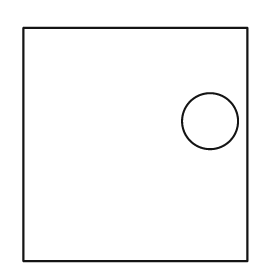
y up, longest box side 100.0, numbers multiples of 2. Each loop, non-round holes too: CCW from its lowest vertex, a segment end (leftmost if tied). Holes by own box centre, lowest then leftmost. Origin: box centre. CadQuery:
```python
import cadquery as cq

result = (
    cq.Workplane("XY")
    .moveTo(-48.0, -50.0)
    .lineTo(48.0, -50.0)
    .lineTo(48.0, 50.0)
    .lineTo(-48.0, 50.0)
    .close()
    .moveTo(32.0, 10.0)
    .circle(12.0)
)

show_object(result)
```